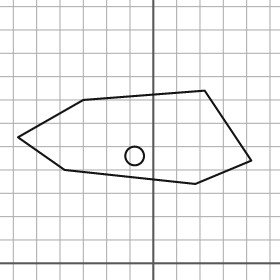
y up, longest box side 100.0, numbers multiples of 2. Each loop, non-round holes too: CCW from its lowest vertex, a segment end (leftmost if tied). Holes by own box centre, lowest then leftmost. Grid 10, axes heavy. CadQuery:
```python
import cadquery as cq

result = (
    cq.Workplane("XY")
    .moveTo(18.0, 34.0)
    .lineTo(42.0, 44.0)
    .lineTo(22.0, 74.0)
    .lineTo(-30.0, 70.0)
    .lineTo(-58.0, 54.0)
    .lineTo(-38.0, 40.0)
    .close()
    .moveTo(-8.0, 46.0)
    .circle(4.0)
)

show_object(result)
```